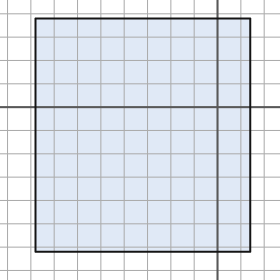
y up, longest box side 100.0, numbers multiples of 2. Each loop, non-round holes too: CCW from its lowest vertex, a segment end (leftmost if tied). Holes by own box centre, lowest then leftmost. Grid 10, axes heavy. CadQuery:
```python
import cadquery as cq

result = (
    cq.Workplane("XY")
    .moveTo(-78.0, -62.0)
    .lineTo(14.0, -62.0)
    .lineTo(14.0, 38.0)
    .lineTo(-78.0, 38.0)
    .close()
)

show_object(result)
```